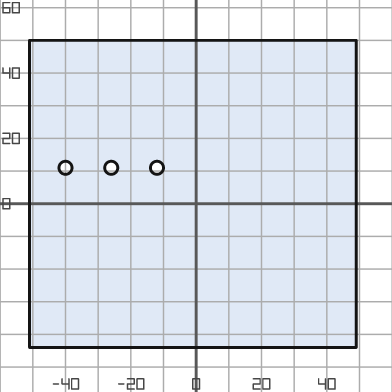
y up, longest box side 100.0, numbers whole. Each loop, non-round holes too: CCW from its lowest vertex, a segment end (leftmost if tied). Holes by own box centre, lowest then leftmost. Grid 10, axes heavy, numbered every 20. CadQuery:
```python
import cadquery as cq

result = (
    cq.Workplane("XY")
    .moveTo(-51.0, -44.0)
    .lineTo(49.0, -44.0)
    .lineTo(49.0, 50.0)
    .lineTo(-51.0, 50.0)
    .close()
    .moveTo(-40.0, 11.0)
    .circle(2.0)
    .moveTo(-26.0, 11.0)
    .circle(2.0)
    .moveTo(-12.0, 11.0)
    .circle(2.0)
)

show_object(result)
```